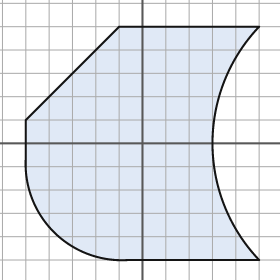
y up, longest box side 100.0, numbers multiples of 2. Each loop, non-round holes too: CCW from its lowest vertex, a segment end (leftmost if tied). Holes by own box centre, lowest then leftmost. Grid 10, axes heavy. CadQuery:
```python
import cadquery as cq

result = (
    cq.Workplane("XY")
    .moveTo(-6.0, -50.0)
    .lineTo(50.0, -50.0)
    .threePointArc((30.0, 0.0), (50.0, 50.0))
    .lineTo(-10.0, 50.0)
    .lineTo(-50.0, 10.0)
    .lineTo(-50.0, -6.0)
    .threePointArc((-38.0, -38.0), (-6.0, -50.0))
    .close()
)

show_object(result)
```